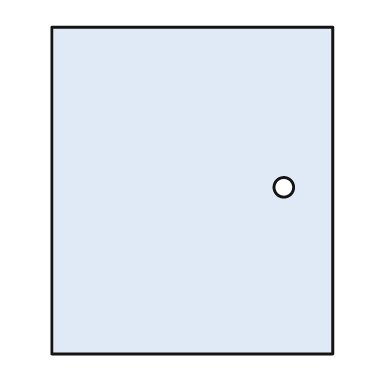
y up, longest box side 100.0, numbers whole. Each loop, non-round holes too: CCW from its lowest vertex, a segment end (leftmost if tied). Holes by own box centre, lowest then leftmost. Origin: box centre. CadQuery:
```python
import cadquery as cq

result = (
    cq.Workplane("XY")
    .moveTo(-43.0, -50.0)
    .lineTo(43.0, -50.0)
    .lineTo(43.0, 50.0)
    .lineTo(-43.0, 50.0)
    .close()
    .moveTo(28.0, 1.0)
    .circle(3.0)
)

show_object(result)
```